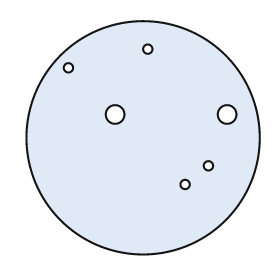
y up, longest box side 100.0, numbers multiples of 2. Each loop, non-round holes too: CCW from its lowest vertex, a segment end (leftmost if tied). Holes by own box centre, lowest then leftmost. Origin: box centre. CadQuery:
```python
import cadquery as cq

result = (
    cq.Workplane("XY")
    .moveTo(0.0, 0.0)
    .circle(50.0)
    .moveTo(18.0, -20.0)
    .circle(2.0)
    .moveTo(28.0, -12.0)
    .circle(2.0)
    .moveTo(-12.0, 10.0)
    .circle(4.0)
    .moveTo(36.0, 10.0)
    .circle(4.0)
    .moveTo(-32.0, 30.0)
    .circle(2.0)
    .moveTo(2.0, 38.0)
    .circle(2.0)
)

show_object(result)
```